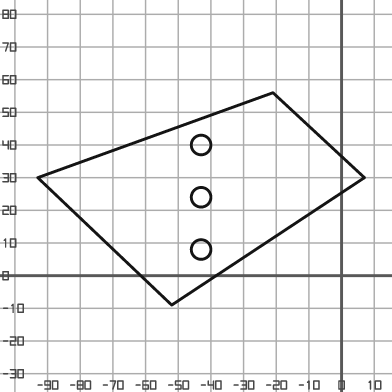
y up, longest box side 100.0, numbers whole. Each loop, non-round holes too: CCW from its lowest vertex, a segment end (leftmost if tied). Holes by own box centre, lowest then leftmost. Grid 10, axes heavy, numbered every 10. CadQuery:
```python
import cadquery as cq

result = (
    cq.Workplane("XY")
    .moveTo(-52.0, -9.0)
    .lineTo(7.0, 30.0)
    .lineTo(-21.0, 56.0)
    .lineTo(-93.0, 30.0)
    .close()
    .moveTo(-43.0, 8.0)
    .circle(3.0)
    .moveTo(-43.0, 24.0)
    .circle(3.0)
    .moveTo(-43.0, 40.0)
    .circle(3.0)
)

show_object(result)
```